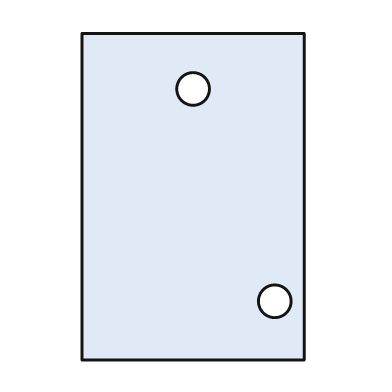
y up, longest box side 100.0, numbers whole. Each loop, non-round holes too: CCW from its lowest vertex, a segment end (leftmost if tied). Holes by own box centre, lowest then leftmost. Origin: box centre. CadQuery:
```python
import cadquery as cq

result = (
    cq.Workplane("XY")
    .moveTo(-34.0, -50.0)
    .lineTo(34.0, -50.0)
    .lineTo(34.0, 50.0)
    .lineTo(-34.0, 50.0)
    .close()
    .moveTo(25.0, -32.0)
    .circle(5.0)
    .moveTo(0.0, 33.0)
    .circle(5.0)
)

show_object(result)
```